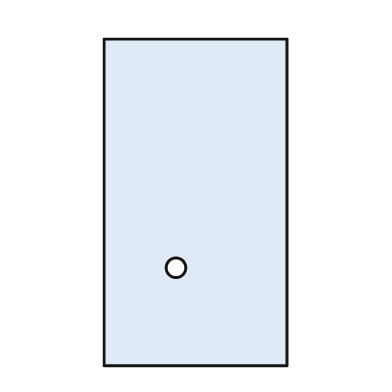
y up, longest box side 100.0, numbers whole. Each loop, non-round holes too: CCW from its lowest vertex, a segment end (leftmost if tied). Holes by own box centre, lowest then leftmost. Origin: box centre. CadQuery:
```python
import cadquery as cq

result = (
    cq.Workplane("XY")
    .moveTo(-28.0, -50.0)
    .lineTo(28.0, -50.0)
    .lineTo(28.0, 50.0)
    .lineTo(-28.0, 50.0)
    .close()
    .moveTo(-6.0, -20.0)
    .circle(3.0)
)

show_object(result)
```